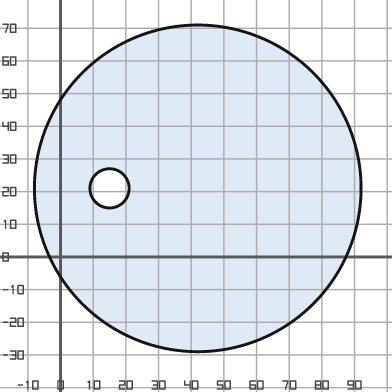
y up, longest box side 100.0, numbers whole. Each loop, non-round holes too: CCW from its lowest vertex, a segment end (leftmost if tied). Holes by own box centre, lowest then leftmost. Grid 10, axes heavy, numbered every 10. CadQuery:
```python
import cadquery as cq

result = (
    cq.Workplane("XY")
    .moveTo(42.0, 21.0)
    .circle(50.0)
    .moveTo(15.0, 21.0)
    .circle(6.0)
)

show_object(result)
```